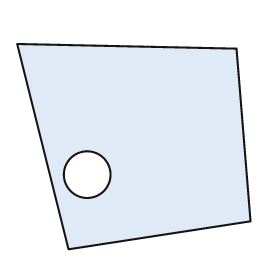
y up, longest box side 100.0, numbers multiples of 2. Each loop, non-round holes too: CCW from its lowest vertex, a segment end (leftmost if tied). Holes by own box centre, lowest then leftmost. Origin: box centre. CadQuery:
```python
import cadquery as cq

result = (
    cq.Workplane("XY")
    .moveTo(-28.0, -44.0)
    .lineTo(50.0, -32.0)
    .lineTo(44.0, 42.0)
    .lineTo(-50.0, 44.0)
    .close()
    .moveTo(-20.0, -12.0)
    .circle(10.0)
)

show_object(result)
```